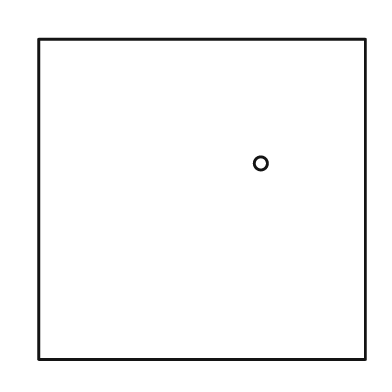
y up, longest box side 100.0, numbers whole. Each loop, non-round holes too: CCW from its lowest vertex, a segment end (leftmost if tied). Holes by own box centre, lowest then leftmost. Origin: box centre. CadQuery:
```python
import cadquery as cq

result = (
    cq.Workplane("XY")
    .moveTo(-50.0, -49.0)
    .lineTo(50.0, -49.0)
    .lineTo(50.0, 49.0)
    .lineTo(-50.0, 49.0)
    .close()
    .moveTo(18.0, 11.0)
    .circle(2.0)
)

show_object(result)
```